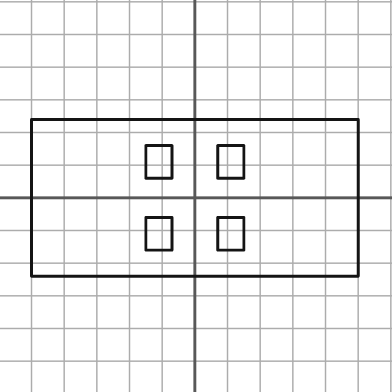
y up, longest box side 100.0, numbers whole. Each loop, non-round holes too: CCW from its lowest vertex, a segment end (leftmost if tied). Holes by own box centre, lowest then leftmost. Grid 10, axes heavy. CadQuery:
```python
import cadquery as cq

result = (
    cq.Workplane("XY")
    .moveTo(-50.0, -24.0)
    .lineTo(50.0, -24.0)
    .lineTo(50.0, 24.0)
    .lineTo(-50.0, 24.0)
    .close()
    .moveTo(-15.0, -16.0)
    .lineTo(-7.0, -16.0)
    .lineTo(-7.0, -6.0)
    .lineTo(-15.0, -6.0)
    .close()
    .moveTo(7.0, -16.0)
    .lineTo(15.0, -16.0)
    .lineTo(15.0, -6.0)
    .lineTo(7.0, -6.0)
    .close()
    .moveTo(-15.0, 6.0)
    .lineTo(-7.0, 6.0)
    .lineTo(-7.0, 16.0)
    .lineTo(-15.0, 16.0)
    .close()
    .moveTo(7.0, 6.0)
    .lineTo(15.0, 6.0)
    .lineTo(15.0, 16.0)
    .lineTo(7.0, 16.0)
    .close()
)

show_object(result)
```